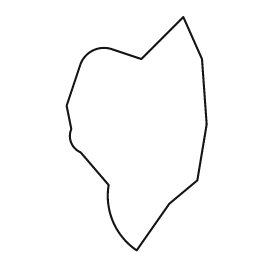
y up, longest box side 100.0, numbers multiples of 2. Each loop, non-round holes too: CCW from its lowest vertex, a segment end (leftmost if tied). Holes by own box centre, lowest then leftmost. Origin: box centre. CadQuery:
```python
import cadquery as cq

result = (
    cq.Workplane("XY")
    .moveTo(0.0, -50.0)
    .lineTo(14.0, -30.0)
    .lineTo(26.0, -20.0)
    .lineTo(30.0, 4.0)
    .lineTo(28.0, 32.0)
    .lineTo(20.0, 50.0)
    .lineTo(2.0, 32.0)
    .lineTo(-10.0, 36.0)
    .threePointArc((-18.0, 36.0), (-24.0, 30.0))
    .lineTo(-30.0, 12.0)
    .lineTo(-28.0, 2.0)
    .threePointArc((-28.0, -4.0), (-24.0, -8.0))
    .lineTo(-12.0, -22.0)
    .threePointArc((-10.0, -38.0), (0.0, -50.0))
    .close()
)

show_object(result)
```